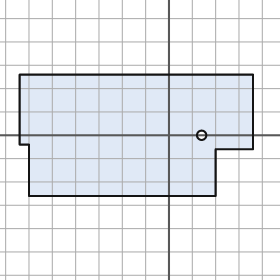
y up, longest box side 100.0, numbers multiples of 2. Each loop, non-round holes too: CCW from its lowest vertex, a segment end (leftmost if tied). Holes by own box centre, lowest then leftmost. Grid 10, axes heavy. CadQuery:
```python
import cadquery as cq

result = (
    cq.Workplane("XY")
    .moveTo(-60.0, -26.0)
    .lineTo(20.0, -26.0)
    .lineTo(20.0, -6.0)
    .lineTo(36.0, -6.0)
    .lineTo(36.0, 26.0)
    .lineTo(-64.0, 26.0)
    .lineTo(-64.0, -4.0)
    .lineTo(-60.0, -4.0)
    .close()
    .moveTo(14.0, 0.0)
    .circle(2.0)
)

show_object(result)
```